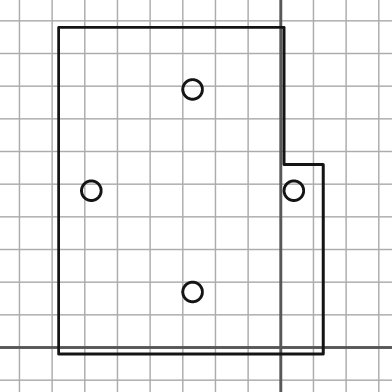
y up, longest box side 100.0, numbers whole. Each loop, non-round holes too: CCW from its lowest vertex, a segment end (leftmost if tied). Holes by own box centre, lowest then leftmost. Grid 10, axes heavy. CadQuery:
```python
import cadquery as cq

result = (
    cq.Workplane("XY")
    .moveTo(-68.0, -2.0)
    .lineTo(13.0, -2.0)
    .lineTo(13.0, 56.0)
    .lineTo(1.0, 56.0)
    .lineTo(1.0, 98.0)
    .lineTo(-68.0, 98.0)
    .close()
    .moveTo(-27.0, 17.0)
    .circle(3.0)
    .moveTo(-58.0, 48.0)
    .circle(3.0)
    .moveTo(4.0, 48.0)
    .circle(3.0)
    .moveTo(-27.0, 79.0)
    .circle(3.0)
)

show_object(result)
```